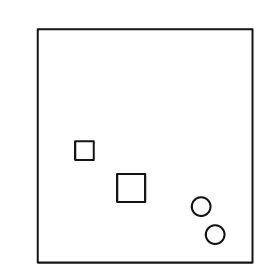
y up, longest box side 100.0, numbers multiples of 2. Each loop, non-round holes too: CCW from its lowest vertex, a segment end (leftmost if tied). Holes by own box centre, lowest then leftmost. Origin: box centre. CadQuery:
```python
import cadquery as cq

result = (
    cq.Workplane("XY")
    .moveTo(-46.0, -50.0)
    .lineTo(46.0, -50.0)
    .lineTo(46.0, 50.0)
    .lineTo(-46.0, 50.0)
    .close()
    .moveTo(30.0, -38.0)
    .circle(4.0)
    .moveTo(24.0, -26.0)
    .circle(4.0)
    .moveTo(-12.0, -24.0)
    .lineTo(0.0, -24.0)
    .lineTo(0.0, -12.0)
    .lineTo(-12.0, -12.0)
    .close()
    .moveTo(-30.0, -6.0)
    .lineTo(-22.0, -6.0)
    .lineTo(-22.0, 2.0)
    .lineTo(-30.0, 2.0)
    .close()
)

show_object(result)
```